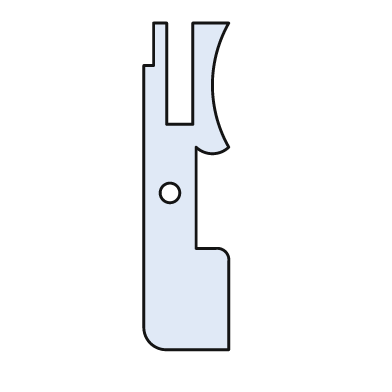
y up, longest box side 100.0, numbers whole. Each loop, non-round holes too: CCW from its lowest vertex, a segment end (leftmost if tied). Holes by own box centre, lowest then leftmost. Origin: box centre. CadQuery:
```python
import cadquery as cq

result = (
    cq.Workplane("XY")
    .moveTo(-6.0, -50.0)
    .lineTo(13.0, -50.0)
    .lineTo(13.0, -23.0)
    .threePointArc((12.0, -20.0), (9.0, -19.0))
    .lineTo(3.0, -19.0)
    .lineTo(3.0, 12.0)
    .threePointArc((8.0, 10.0), (13.0, 12.0))
    .threePointArc((8.0, 31.0), (13.0, 50.0))
    .lineTo(2.0, 50.0)
    .lineTo(2.0, 19.0)
    .lineTo(-6.0, 19.0)
    .lineTo(-6.0, 50.0)
    .lineTo(-10.0, 50.0)
    .lineTo(-10.0, 37.0)
    .lineTo(-13.0, 37.0)
    .lineTo(-13.0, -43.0)
    .threePointArc((-11.0, -48.0), (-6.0, -50.0))
    .close()
    .moveTo(-5.0, -2.0)
    .circle(3.0)
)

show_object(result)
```